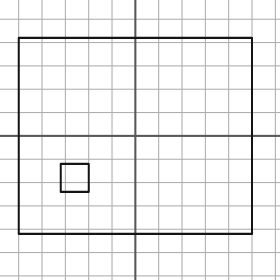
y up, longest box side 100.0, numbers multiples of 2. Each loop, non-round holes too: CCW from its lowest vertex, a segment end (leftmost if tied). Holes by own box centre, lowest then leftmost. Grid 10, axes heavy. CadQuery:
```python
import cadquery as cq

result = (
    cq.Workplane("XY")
    .moveTo(-50.0, -42.0)
    .lineTo(50.0, -42.0)
    .lineTo(50.0, 42.0)
    .lineTo(-50.0, 42.0)
    .close()
    .moveTo(-32.0, -24.0)
    .lineTo(-20.0, -24.0)
    .lineTo(-20.0, -12.0)
    .lineTo(-32.0, -12.0)
    .close()
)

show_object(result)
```